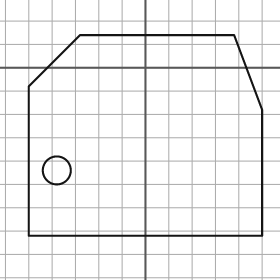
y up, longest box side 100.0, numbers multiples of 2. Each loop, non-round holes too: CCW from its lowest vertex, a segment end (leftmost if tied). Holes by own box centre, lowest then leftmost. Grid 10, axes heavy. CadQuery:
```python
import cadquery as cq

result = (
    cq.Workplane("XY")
    .moveTo(-50.0, -72.0)
    .lineTo(50.0, -72.0)
    .lineTo(50.0, -18.0)
    .lineTo(38.0, 14.0)
    .lineTo(-28.0, 14.0)
    .lineTo(-50.0, -8.0)
    .close()
    .moveTo(-38.0, -44.0)
    .circle(6.0)
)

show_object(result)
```